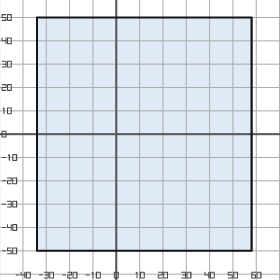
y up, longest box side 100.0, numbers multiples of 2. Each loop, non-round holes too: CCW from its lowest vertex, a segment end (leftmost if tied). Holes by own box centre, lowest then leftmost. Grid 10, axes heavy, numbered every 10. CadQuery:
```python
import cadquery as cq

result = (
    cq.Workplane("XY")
    .moveTo(-34.0, -50.0)
    .lineTo(58.0, -50.0)
    .lineTo(58.0, 50.0)
    .lineTo(-34.0, 50.0)
    .close()
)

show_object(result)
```